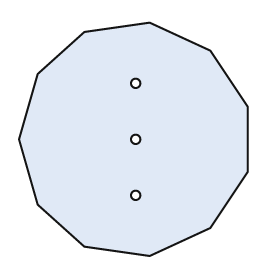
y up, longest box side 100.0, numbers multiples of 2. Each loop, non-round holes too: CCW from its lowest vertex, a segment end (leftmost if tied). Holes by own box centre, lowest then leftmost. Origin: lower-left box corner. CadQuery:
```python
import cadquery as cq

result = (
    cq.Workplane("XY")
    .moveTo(56.0, 0.0)
    .lineTo(82.0, 12.0)
    .lineTo(98.0, 36.0)
    .lineTo(98.0, 64.0)
    .lineTo(82.0, 88.0)
    .lineTo(56.0, 100.0)
    .lineTo(28.0, 96.0)
    .lineTo(8.0, 78.0)
    .lineTo(0.0, 50.0)
    .lineTo(8.0, 22.0)
    .lineTo(28.0, 4.0)
    .close()
    .moveTo(50.0, 26.0)
    .circle(2.0)
    .moveTo(50.0, 50.0)
    .circle(2.0)
    .moveTo(50.0, 74.0)
    .circle(2.0)
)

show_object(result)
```